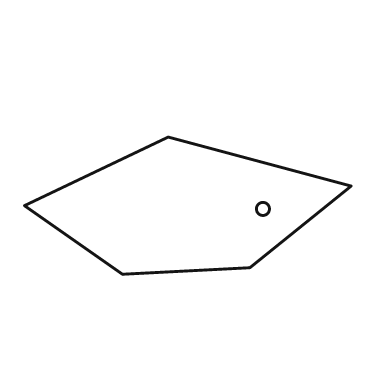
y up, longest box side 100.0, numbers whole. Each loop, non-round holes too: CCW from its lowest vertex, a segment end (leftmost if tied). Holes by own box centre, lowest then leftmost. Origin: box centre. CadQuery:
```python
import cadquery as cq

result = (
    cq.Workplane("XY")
    .moveTo(-20.0, -21.0)
    .lineTo(19.0, -19.0)
    .lineTo(50.0, 6.0)
    .lineTo(-6.0, 21.0)
    .lineTo(-50.0, 0.0)
    .close()
    .moveTo(23.0, -1.0)
    .circle(2.0)
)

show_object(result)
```